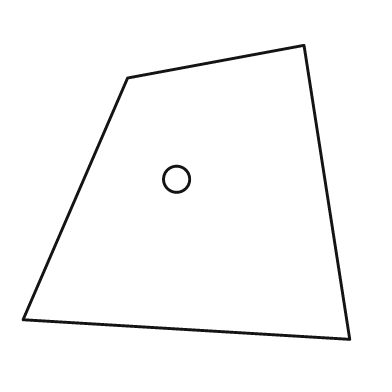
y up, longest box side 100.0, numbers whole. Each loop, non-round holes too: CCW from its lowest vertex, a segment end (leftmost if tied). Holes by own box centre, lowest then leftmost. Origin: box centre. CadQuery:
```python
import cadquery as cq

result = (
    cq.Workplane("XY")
    .moveTo(50.0, -45.0)
    .lineTo(36.0, 45.0)
    .lineTo(-18.0, 35.0)
    .lineTo(-50.0, -39.0)
    .close()
    .moveTo(-3.0, 4.0)
    .circle(4.0)
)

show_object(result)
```